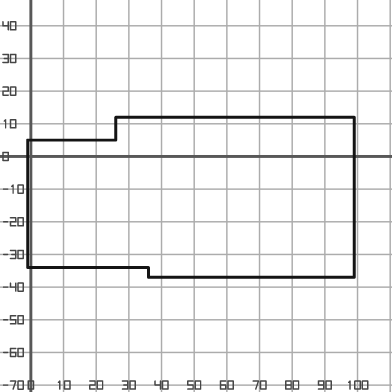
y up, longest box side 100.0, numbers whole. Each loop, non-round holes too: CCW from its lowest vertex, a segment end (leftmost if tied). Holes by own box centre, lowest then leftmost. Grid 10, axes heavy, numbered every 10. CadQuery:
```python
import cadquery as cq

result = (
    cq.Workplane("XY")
    .moveTo(36.0, -37.0)
    .lineTo(99.0, -37.0)
    .lineTo(99.0, 12.0)
    .lineTo(26.0, 12.0)
    .lineTo(26.0, 5.0)
    .lineTo(-1.0, 5.0)
    .lineTo(-1.0, -34.0)
    .lineTo(36.0, -34.0)
    .close()
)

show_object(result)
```